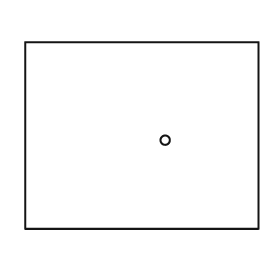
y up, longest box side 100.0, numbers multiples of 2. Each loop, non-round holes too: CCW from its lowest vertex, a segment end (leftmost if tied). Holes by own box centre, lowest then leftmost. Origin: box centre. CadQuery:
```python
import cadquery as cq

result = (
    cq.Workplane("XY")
    .moveTo(-50.0, -40.0)
    .lineTo(50.0, -40.0)
    .lineTo(50.0, 40.0)
    .lineTo(-50.0, 40.0)
    .close()
    .moveTo(10.0, -2.0)
    .circle(2.0)
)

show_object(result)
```